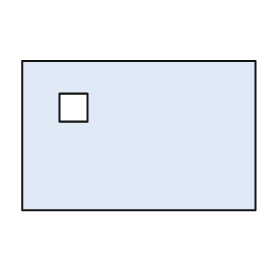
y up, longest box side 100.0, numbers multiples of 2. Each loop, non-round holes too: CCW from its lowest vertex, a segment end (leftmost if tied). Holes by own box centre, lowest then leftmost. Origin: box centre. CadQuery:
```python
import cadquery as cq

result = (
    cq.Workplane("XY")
    .moveTo(-50.0, -32.0)
    .lineTo(50.0, -32.0)
    .lineTo(50.0, 32.0)
    .lineTo(-50.0, 32.0)
    .close()
    .moveTo(-34.0, 6.0)
    .lineTo(-22.0, 6.0)
    .lineTo(-22.0, 18.0)
    .lineTo(-34.0, 18.0)
    .close()
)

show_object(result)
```